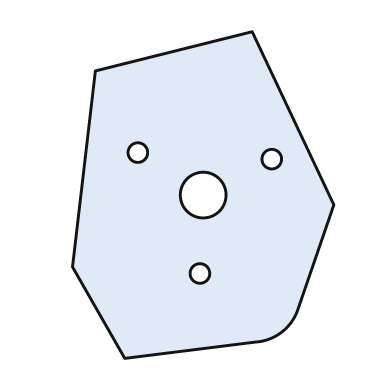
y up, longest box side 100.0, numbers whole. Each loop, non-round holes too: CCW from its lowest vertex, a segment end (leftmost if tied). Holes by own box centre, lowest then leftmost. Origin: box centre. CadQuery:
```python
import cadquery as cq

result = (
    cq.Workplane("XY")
    .moveTo(-24.0, -50.0)
    .lineTo(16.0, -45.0)
    .threePointArc((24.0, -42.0), (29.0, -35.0))
    .lineTo(40.0, -3.0)
    .lineTo(15.0, 50.0)
    .lineTo(-33.0, 38.0)
    .lineTo(-40.0, -22.0)
    .close()
    .moveTo(-1.0, -24.0)
    .circle(3.0)
    .moveTo(0.0, 0.0)
    .circle(7.0)
    .moveTo(21.0, 11.0)
    .circle(3.0)
    .moveTo(-20.0, 13.0)
    .circle(3.0)
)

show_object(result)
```